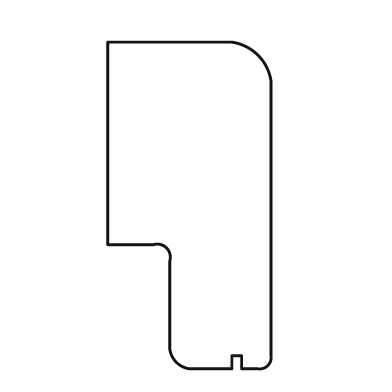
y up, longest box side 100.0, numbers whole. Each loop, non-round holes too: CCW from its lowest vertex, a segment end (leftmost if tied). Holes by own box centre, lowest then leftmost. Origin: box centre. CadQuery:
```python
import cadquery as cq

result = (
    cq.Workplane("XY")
    .moveTo(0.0, -50.0)
    .lineTo(13.0, -50.0)
    .lineTo(13.0, -46.0)
    .lineTo(16.0, -46.0)
    .lineTo(16.0, -50.0)
    .lineTo(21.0, -50.0)
    .threePointArc((24.0, -49.0), (25.0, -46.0))
    .lineTo(25.0, 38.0)
    .threePointArc((21.0, 46.0), (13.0, 50.0))
    .lineTo(-25.0, 50.0)
    .lineTo(-25.0, -12.0)
    .lineTo(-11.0, -12.0)
    .threePointArc((-7.0, -13.0), (-6.0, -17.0))
    .lineTo(-6.0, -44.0)
    .threePointArc((-4.0, -48.0), (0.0, -50.0))
    .close()
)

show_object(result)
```